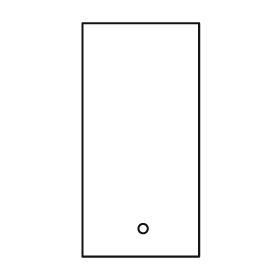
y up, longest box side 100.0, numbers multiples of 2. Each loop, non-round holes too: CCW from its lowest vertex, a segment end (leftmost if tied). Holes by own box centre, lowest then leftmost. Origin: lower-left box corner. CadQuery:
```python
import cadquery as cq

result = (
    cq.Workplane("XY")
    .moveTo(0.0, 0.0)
    .lineTo(50.0, 0.0)
    .lineTo(50.0, 100.0)
    .lineTo(0.0, 100.0)
    .close()
    .moveTo(26.0, 12.0)
    .circle(2.0)
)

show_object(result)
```